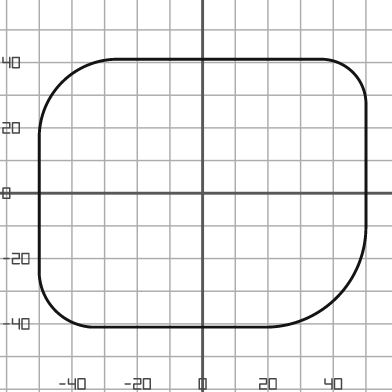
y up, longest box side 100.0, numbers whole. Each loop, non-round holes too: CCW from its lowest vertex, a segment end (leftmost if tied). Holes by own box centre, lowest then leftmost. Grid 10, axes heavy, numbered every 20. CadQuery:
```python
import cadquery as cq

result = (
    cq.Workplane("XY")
    .moveTo(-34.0, -41.0)
    .lineTo(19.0, -41.0)
    .threePointArc((41.0, -32.0), (50.0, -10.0))
    .lineTo(50.0, 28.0)
    .threePointArc((46.0, 37.0), (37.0, 41.0))
    .lineTo(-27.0, 41.0)
    .threePointArc((-43.0, 34.0), (-50.0, 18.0))
    .lineTo(-50.0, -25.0)
    .threePointArc((-45.0, -36.0), (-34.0, -41.0))
    .close()
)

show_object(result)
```